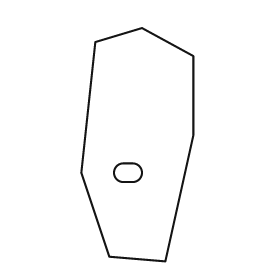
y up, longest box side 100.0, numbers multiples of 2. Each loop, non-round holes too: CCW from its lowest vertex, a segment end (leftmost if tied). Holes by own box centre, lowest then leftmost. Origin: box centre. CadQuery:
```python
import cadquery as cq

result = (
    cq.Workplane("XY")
    .moveTo(12.0, -50.0)
    .lineTo(24.0, 4.0)
    .lineTo(24.0, 38.0)
    .lineTo(2.0, 50.0)
    .lineTo(-18.0, 44.0)
    .lineTo(-24.0, -12.0)
    .lineTo(-12.0, -48.0)
    .close()
    .moveTo(-6.0, -16.0)
    .lineTo(-2.0, -16.0)
    .threePointArc((2.0, -12.0), (-2.0, -8.0))
    .lineTo(-6.0, -8.0)
    .threePointArc((-10.0, -12.0), (-6.0, -16.0))
    .close()
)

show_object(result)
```